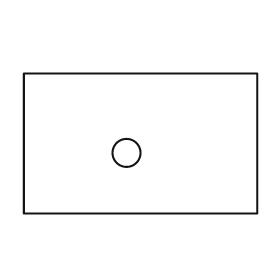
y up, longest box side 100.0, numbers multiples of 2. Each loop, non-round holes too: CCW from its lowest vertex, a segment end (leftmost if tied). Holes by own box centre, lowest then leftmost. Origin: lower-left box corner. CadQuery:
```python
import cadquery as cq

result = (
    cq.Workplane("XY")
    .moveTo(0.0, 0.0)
    .lineTo(100.0, 0.0)
    .lineTo(100.0, 60.0)
    .lineTo(0.0, 60.0)
    .close()
    .moveTo(44.0, 26.0)
    .circle(6.0)
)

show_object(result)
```